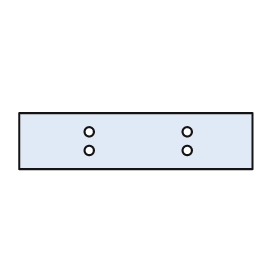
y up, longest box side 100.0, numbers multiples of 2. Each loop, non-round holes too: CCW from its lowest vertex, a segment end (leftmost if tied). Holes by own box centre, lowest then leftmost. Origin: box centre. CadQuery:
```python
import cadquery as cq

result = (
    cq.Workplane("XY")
    .moveTo(-50.0, -12.0)
    .lineTo(50.0, -12.0)
    .lineTo(50.0, 12.0)
    .lineTo(-50.0, 12.0)
    .close()
    .moveTo(-20.0, -4.0)
    .circle(2.0)
    .moveTo(22.0, -4.0)
    .circle(2.0)
    .moveTo(-20.0, 4.0)
    .circle(2.0)
    .moveTo(22.0, 4.0)
    .circle(2.0)
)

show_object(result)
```